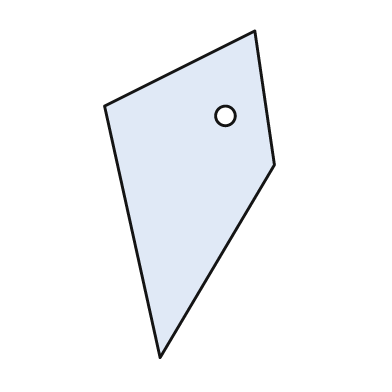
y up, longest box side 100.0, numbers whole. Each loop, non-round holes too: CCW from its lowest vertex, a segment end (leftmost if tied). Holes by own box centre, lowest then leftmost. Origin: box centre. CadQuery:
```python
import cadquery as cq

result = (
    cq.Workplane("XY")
    .moveTo(-9.0, -50.0)
    .lineTo(26.0, 9.0)
    .lineTo(20.0, 50.0)
    .lineTo(-26.0, 27.0)
    .close()
    .moveTo(11.0, 24.0)
    .circle(3.0)
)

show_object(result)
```